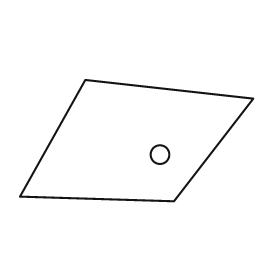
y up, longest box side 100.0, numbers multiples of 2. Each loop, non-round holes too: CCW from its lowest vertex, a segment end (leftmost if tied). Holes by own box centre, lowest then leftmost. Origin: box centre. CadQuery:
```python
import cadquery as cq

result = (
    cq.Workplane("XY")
    .moveTo(16.0, -26.0)
    .lineTo(50.0, 18.0)
    .lineTo(-22.0, 26.0)
    .lineTo(-50.0, -24.0)
    .close()
    .moveTo(10.0, -6.0)
    .circle(4.0)
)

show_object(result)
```